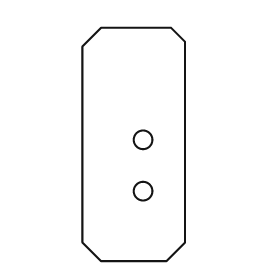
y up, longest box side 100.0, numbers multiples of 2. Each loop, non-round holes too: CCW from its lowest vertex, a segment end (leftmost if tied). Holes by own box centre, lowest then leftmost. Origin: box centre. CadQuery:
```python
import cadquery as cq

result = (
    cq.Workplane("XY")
    .moveTo(-14.0, -50.0)
    .lineTo(14.0, -50.0)
    .lineTo(22.0, -42.0)
    .lineTo(22.0, 44.0)
    .lineTo(16.0, 50.0)
    .lineTo(-14.0, 50.0)
    .lineTo(-22.0, 42.0)
    .lineTo(-22.0, -42.0)
    .close()
    .moveTo(4.0, -20.0)
    .circle(4.0)
    .moveTo(4.0, 2.0)
    .circle(4.0)
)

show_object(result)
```